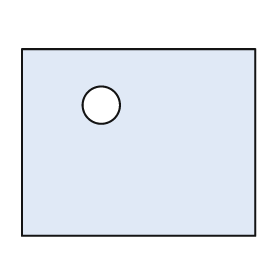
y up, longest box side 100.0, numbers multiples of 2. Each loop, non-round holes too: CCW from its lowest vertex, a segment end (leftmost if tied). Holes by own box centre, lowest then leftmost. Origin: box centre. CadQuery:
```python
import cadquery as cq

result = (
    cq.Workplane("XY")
    .moveTo(-50.0, -40.0)
    .lineTo(50.0, -40.0)
    .lineTo(50.0, 40.0)
    .lineTo(-50.0, 40.0)
    .close()
    .moveTo(-16.0, 16.0)
    .circle(8.0)
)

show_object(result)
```